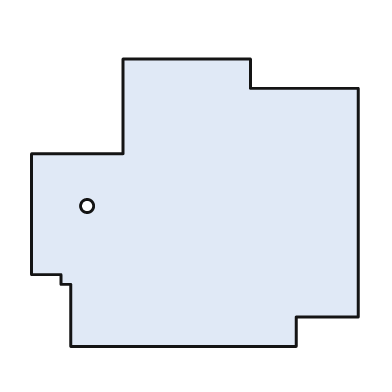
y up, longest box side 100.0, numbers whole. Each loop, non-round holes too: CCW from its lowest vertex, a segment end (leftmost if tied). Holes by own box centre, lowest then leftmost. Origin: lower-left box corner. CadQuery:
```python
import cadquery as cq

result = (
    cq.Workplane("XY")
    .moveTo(12.0, 0.0)
    .lineTo(81.0, 0.0)
    .lineTo(81.0, 9.0)
    .lineTo(100.0, 9.0)
    .lineTo(100.0, 79.0)
    .lineTo(67.0, 79.0)
    .lineTo(67.0, 88.0)
    .lineTo(28.0, 88.0)
    .lineTo(28.0, 59.0)
    .lineTo(0.0, 59.0)
    .lineTo(0.0, 22.0)
    .lineTo(9.0, 22.0)
    .lineTo(9.0, 19.0)
    .lineTo(12.0, 19.0)
    .close()
    .moveTo(17.0, 43.0)
    .circle(2.0)
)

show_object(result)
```